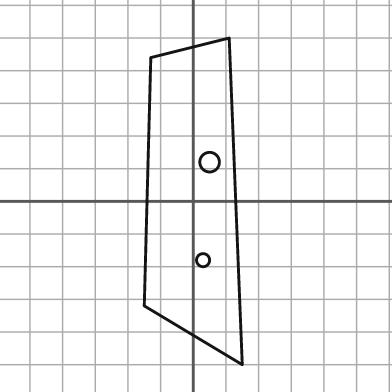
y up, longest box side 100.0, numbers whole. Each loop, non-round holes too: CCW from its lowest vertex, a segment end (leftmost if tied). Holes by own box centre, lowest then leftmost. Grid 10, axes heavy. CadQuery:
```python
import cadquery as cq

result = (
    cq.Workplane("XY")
    .moveTo(15.0, -50.0)
    .lineTo(11.0, 50.0)
    .lineTo(-13.0, 44.0)
    .lineTo(-15.0, -32.0)
    .close()
    .moveTo(3.0, -18.0)
    .circle(2.0)
    .moveTo(5.0, 12.0)
    .circle(3.0)
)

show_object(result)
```